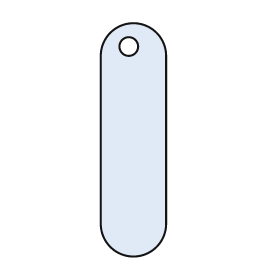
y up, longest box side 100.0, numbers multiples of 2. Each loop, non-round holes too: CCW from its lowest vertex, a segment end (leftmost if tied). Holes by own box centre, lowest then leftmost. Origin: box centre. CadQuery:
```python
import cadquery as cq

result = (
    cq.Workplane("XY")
    .moveTo(-14.0, -36.0)
    .threePointArc((0.0, -50.0), (14.0, -36.0))
    .lineTo(14.0, 36.0)
    .threePointArc((0.0, 50.0), (-14.0, 36.0))
    .close()
    .moveTo(-2.0, 40.0)
    .circle(4.0)
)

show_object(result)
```